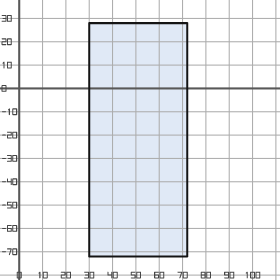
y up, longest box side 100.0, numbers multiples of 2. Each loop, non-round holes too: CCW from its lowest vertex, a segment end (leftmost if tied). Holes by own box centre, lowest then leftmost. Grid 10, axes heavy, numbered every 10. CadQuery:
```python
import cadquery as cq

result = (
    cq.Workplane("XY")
    .moveTo(30.0, -72.0)
    .lineTo(72.0, -72.0)
    .lineTo(72.0, 28.0)
    .lineTo(30.0, 28.0)
    .close()
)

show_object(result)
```